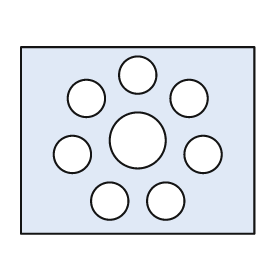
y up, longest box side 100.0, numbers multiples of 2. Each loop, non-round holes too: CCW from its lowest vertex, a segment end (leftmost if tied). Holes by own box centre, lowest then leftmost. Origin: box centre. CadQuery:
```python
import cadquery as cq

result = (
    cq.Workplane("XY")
    .moveTo(-50.0, -40.0)
    .lineTo(50.0, -40.0)
    .lineTo(50.0, 40.0)
    .lineTo(-50.0, 40.0)
    .close()
    .moveTo(-12.0, -26.0)
    .circle(8.0)
    .moveTo(12.0, -26.0)
    .circle(8.0)
    .moveTo(-28.0, -6.0)
    .circle(8.0)
    .moveTo(28.0, -6.0)
    .circle(8.0)
    .moveTo(0.0, 0.0)
    .circle(12.0)
    .moveTo(-22.0, 18.0)
    .circle(8.0)
    .moveTo(22.0, 18.0)
    .circle(8.0)
    .moveTo(0.0, 28.0)
    .circle(8.0)
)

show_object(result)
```